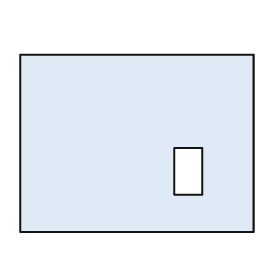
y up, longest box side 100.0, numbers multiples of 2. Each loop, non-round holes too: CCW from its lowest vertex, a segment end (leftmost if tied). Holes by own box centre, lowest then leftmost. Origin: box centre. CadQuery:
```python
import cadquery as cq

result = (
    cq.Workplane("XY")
    .moveTo(-50.0, -38.0)
    .lineTo(50.0, -38.0)
    .lineTo(50.0, 38.0)
    .lineTo(-50.0, 38.0)
    .close()
    .moveTo(16.0, -22.0)
    .lineTo(28.0, -22.0)
    .lineTo(28.0, -2.0)
    .lineTo(16.0, -2.0)
    .close()
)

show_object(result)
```